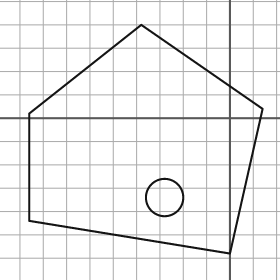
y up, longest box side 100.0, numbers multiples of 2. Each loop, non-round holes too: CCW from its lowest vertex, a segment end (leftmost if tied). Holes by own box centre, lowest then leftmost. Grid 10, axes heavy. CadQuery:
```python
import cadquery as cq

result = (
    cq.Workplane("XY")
    .moveTo(0.0, -58.0)
    .lineTo(14.0, 4.0)
    .lineTo(-38.0, 40.0)
    .lineTo(-86.0, 2.0)
    .lineTo(-86.0, -44.0)
    .close()
    .moveTo(-28.0, -34.0)
    .circle(8.0)
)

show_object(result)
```